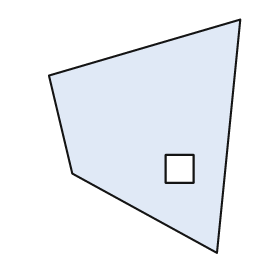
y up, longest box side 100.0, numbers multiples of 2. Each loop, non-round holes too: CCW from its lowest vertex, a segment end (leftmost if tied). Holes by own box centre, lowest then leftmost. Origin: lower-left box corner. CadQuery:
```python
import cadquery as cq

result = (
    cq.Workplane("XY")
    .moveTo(72.0, 0.0)
    .lineTo(82.0, 100.0)
    .lineTo(0.0, 76.0)
    .lineTo(10.0, 34.0)
    .close()
    .moveTo(50.0, 30.0)
    .lineTo(62.0, 30.0)
    .lineTo(62.0, 42.0)
    .lineTo(50.0, 42.0)
    .close()
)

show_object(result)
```